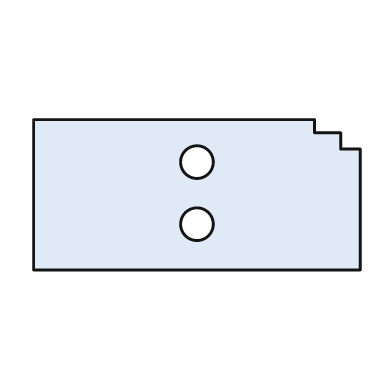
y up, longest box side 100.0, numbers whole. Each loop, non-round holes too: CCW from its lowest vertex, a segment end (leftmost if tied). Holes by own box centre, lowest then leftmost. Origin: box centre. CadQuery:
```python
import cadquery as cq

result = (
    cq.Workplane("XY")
    .moveTo(-50.0, -23.0)
    .lineTo(50.0, -23.0)
    .lineTo(50.0, 14.0)
    .lineTo(44.0, 14.0)
    .lineTo(44.0, 19.0)
    .lineTo(36.0, 19.0)
    .lineTo(36.0, 23.0)
    .lineTo(-50.0, 23.0)
    .close()
    .moveTo(0.0, -9.0)
    .circle(5.0)
    .moveTo(0.0, 10.0)
    .circle(5.0)
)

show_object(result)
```